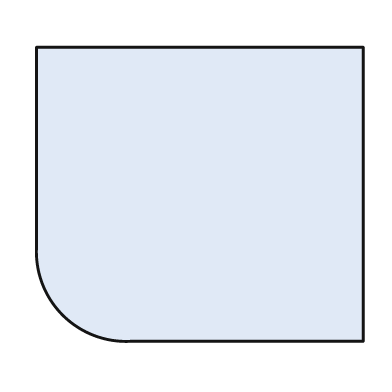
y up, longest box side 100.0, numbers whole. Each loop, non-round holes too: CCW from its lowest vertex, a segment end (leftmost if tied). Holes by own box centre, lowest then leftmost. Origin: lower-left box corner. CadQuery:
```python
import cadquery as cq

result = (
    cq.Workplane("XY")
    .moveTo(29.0, 0.0)
    .lineTo(100.0, 0.0)
    .lineTo(100.0, 90.0)
    .lineTo(0.0, 90.0)
    .lineTo(0.0, 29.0)
    .threePointArc((8.0, 8.0), (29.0, 0.0))
    .close()
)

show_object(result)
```